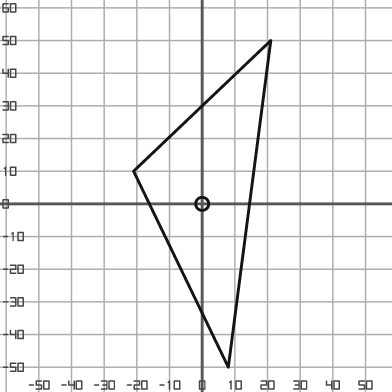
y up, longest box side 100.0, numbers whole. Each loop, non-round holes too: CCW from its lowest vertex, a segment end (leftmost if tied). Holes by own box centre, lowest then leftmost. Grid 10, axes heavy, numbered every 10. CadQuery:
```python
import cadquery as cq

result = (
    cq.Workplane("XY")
    .moveTo(8.0, -50.0)
    .lineTo(21.0, 50.0)
    .lineTo(-21.0, 10.0)
    .close()
    .moveTo(0.0, 0.0)
    .circle(2.0)
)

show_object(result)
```